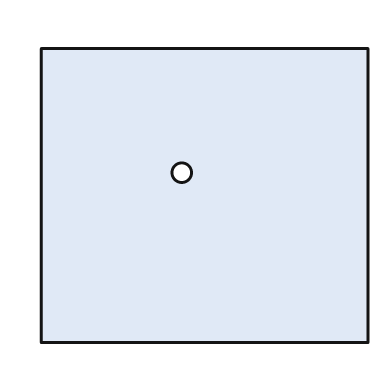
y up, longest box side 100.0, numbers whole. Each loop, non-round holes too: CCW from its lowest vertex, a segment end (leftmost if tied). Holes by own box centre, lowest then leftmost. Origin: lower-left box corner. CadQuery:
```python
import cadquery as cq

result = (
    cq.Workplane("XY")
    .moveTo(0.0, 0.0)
    .lineTo(100.0, 0.0)
    .lineTo(100.0, 90.0)
    .lineTo(0.0, 90.0)
    .close()
    .moveTo(43.0, 52.0)
    .circle(3.0)
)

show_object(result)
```